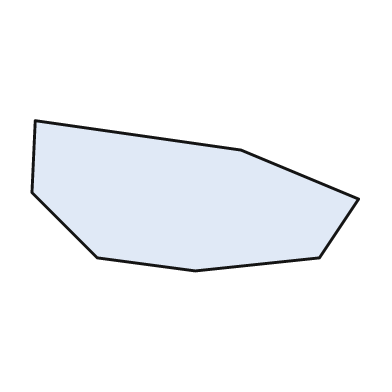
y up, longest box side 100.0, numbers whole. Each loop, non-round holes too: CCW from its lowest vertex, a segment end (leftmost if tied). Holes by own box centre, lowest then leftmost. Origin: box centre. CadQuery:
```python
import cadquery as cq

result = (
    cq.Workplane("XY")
    .moveTo(0.0, -23.0)
    .lineTo(38.0, -19.0)
    .lineTo(50.0, -1.0)
    .lineTo(14.0, 14.0)
    .lineTo(-49.0, 23.0)
    .lineTo(-50.0, 1.0)
    .lineTo(-30.0, -19.0)
    .close()
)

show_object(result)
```